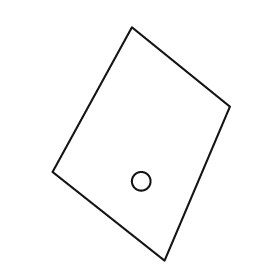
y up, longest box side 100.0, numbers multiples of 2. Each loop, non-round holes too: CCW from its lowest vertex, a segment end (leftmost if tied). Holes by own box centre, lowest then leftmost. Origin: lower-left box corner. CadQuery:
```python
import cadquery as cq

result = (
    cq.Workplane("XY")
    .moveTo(48.0, 0.0)
    .lineTo(76.0, 66.0)
    .lineTo(34.0, 100.0)
    .lineTo(0.0, 38.0)
    .close()
    .moveTo(38.0, 34.0)
    .circle(4.0)
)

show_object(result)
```